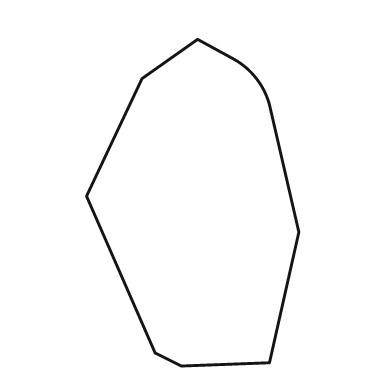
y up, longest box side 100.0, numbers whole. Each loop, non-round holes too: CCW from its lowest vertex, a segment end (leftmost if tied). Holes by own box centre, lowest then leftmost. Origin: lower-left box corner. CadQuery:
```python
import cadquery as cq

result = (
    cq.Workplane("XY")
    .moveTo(29.0, 0.0)
    .lineTo(56.0, 1.0)
    .lineTo(65.0, 41.0)
    .lineTo(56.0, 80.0)
    .threePointArc((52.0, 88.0), (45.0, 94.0))
    .lineTo(34.0, 100.0)
    .lineTo(17.0, 88.0)
    .lineTo(0.0, 52.0)
    .lineTo(21.0, 4.0)
    .close()
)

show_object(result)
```